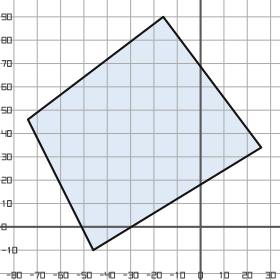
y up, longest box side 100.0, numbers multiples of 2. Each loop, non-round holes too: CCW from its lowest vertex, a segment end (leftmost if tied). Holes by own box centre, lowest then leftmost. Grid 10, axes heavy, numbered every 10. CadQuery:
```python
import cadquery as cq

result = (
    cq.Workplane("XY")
    .moveTo(-46.0, -10.0)
    .lineTo(26.0, 34.0)
    .lineTo(-16.0, 90.0)
    .lineTo(-74.0, 46.0)
    .close()
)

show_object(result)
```